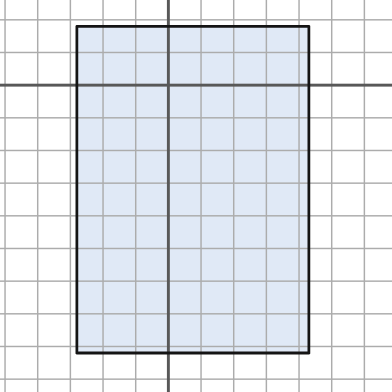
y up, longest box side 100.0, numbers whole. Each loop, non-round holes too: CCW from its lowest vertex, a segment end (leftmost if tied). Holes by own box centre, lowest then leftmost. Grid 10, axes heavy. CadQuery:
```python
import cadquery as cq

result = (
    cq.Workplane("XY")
    .moveTo(-28.0, -82.0)
    .lineTo(43.0, -82.0)
    .lineTo(43.0, 18.0)
    .lineTo(-28.0, 18.0)
    .close()
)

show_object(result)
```